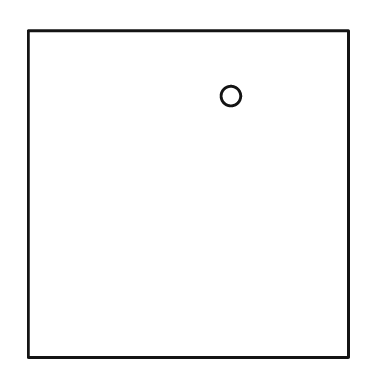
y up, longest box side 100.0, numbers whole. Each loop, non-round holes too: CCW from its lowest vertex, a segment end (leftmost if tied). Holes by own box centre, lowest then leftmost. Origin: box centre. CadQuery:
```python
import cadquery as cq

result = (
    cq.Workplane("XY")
    .moveTo(-49.0, -50.0)
    .lineTo(49.0, -50.0)
    .lineTo(49.0, 50.0)
    .lineTo(-49.0, 50.0)
    .close()
    .moveTo(13.0, 30.0)
    .circle(3.0)
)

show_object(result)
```